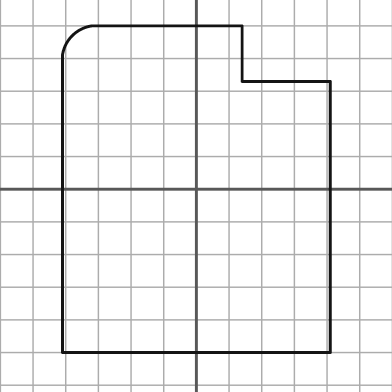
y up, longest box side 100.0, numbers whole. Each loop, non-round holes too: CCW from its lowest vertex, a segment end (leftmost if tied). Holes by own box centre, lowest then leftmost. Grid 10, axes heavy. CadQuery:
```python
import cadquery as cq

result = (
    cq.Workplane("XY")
    .moveTo(-41.0, -50.0)
    .lineTo(41.0, -50.0)
    .lineTo(41.0, 33.0)
    .lineTo(14.0, 33.0)
    .lineTo(14.0, 50.0)
    .lineTo(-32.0, 50.0)
    .threePointArc((-38.0, 47.0), (-41.0, 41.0))
    .close()
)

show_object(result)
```